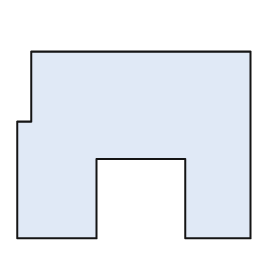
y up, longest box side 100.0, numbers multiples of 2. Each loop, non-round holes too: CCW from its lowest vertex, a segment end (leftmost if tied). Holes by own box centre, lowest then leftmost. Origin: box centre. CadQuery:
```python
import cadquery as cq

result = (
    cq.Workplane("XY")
    .moveTo(-50.0, -40.0)
    .lineTo(-16.0, -40.0)
    .lineTo(-16.0, -6.0)
    .lineTo(22.0, -6.0)
    .lineTo(22.0, -40.0)
    .lineTo(50.0, -40.0)
    .lineTo(50.0, 40.0)
    .lineTo(-44.0, 40.0)
    .lineTo(-44.0, 10.0)
    .lineTo(-50.0, 10.0)
    .close()
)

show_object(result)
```